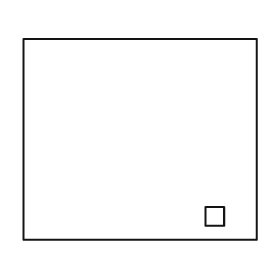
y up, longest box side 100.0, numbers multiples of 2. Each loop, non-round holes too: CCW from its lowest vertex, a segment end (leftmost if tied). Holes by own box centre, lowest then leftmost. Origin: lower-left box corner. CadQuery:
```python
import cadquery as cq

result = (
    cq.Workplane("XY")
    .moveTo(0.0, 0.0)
    .lineTo(100.0, 0.0)
    .lineTo(100.0, 86.0)
    .lineTo(0.0, 86.0)
    .close()
    .moveTo(78.0, 6.0)
    .lineTo(86.0, 6.0)
    .lineTo(86.0, 14.0)
    .lineTo(78.0, 14.0)
    .close()
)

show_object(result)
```